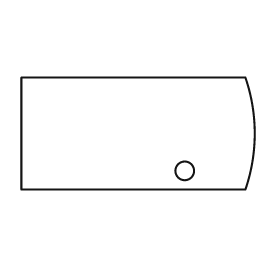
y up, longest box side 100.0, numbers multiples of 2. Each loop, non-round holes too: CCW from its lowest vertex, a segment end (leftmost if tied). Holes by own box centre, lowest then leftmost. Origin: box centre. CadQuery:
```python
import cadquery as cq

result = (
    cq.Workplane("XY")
    .moveTo(-50.0, -24.0)
    .lineTo(46.0, -24.0)
    .threePointArc((50.0, 0.0), (46.0, 24.0))
    .lineTo(-50.0, 24.0)
    .close()
    .moveTo(20.0, -16.0)
    .circle(4.0)
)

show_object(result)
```